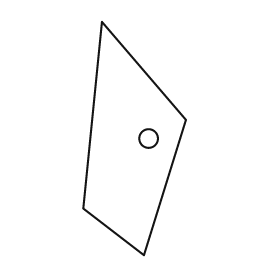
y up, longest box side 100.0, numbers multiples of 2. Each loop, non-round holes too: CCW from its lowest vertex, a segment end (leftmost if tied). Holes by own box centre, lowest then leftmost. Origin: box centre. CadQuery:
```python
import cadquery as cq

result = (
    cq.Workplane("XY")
    .moveTo(4.0, -50.0)
    .lineTo(22.0, 8.0)
    .lineTo(-14.0, 50.0)
    .lineTo(-22.0, -30.0)
    .close()
    .moveTo(6.0, 0.0)
    .circle(4.0)
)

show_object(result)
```